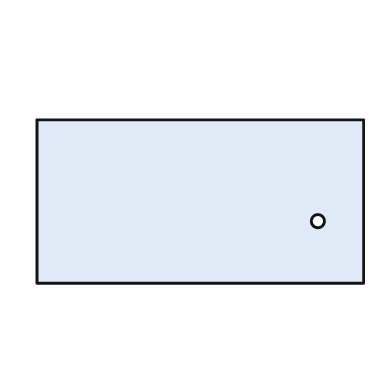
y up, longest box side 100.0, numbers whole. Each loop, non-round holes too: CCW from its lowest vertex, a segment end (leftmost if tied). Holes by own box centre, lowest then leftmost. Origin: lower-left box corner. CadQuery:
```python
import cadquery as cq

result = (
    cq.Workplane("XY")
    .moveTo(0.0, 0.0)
    .lineTo(100.0, 0.0)
    .lineTo(100.0, 50.0)
    .lineTo(0.0, 50.0)
    .close()
    .moveTo(86.0, 19.0)
    .circle(2.0)
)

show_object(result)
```